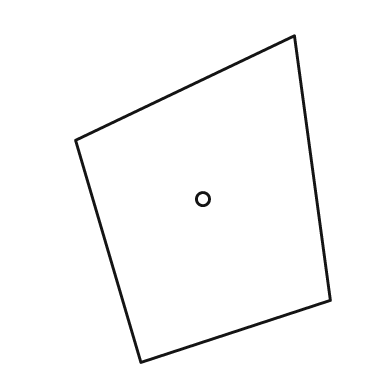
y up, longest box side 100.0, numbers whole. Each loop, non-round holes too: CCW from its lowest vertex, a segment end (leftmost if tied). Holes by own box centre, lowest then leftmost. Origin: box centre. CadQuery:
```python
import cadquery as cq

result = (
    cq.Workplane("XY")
    .moveTo(-19.0, -50.0)
    .lineTo(39.0, -31.0)
    .lineTo(28.0, 50.0)
    .lineTo(-39.0, 18.0)
    .close()
    .moveTo(0.0, 0.0)
    .circle(2.0)
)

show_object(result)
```